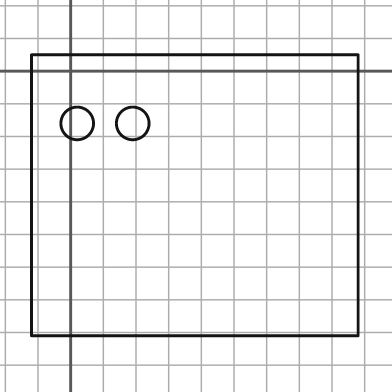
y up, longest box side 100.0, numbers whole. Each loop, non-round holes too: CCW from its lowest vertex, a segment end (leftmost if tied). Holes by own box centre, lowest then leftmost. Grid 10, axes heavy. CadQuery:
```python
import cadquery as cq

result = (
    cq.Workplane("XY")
    .moveTo(-12.0, -81.0)
    .lineTo(88.0, -81.0)
    .lineTo(88.0, 5.0)
    .lineTo(-12.0, 5.0)
    .close()
    .moveTo(2.0, -16.0)
    .circle(5.0)
    .moveTo(19.0, -16.0)
    .circle(5.0)
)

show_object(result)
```